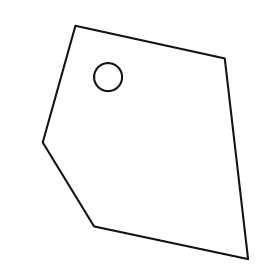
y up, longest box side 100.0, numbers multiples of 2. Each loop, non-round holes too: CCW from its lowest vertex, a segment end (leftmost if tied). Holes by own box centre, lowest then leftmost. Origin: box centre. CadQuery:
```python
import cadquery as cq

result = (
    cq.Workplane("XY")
    .moveTo(44.0, -50.0)
    .lineTo(34.0, 36.0)
    .lineTo(-30.0, 50.0)
    .lineTo(-44.0, 0.0)
    .lineTo(-22.0, -36.0)
    .close()
    .moveTo(-16.0, 28.0)
    .circle(6.0)
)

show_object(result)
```